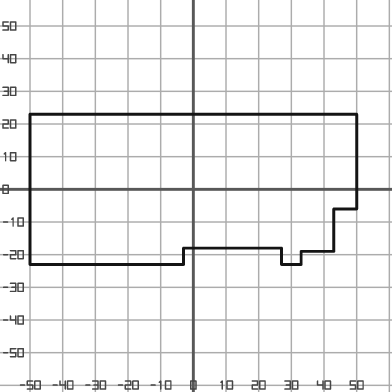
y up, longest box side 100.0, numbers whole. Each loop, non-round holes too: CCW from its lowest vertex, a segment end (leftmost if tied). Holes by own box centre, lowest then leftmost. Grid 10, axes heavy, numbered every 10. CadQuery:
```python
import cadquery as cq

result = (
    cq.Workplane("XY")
    .moveTo(-50.0, -23.0)
    .lineTo(-3.0, -23.0)
    .lineTo(-3.0, -18.0)
    .lineTo(27.0, -18.0)
    .lineTo(27.0, -23.0)
    .lineTo(33.0, -23.0)
    .lineTo(33.0, -19.0)
    .lineTo(43.0, -19.0)
    .lineTo(43.0, -6.0)
    .lineTo(50.0, -6.0)
    .lineTo(50.0, 23.0)
    .lineTo(-50.0, 23.0)
    .close()
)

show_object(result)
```